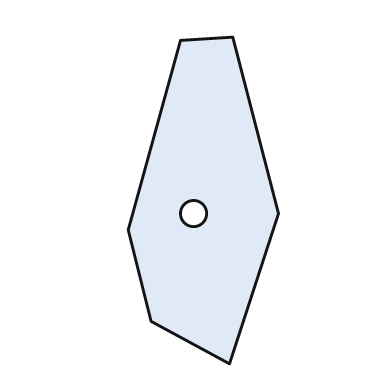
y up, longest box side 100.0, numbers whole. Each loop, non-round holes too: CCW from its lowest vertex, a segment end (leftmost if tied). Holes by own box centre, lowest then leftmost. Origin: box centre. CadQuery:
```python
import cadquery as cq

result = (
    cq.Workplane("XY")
    .moveTo(8.0, -50.0)
    .lineTo(23.0, -4.0)
    .lineTo(9.0, 50.0)
    .lineTo(-7.0, 49.0)
    .lineTo(-23.0, -9.0)
    .lineTo(-16.0, -37.0)
    .close()
    .moveTo(-3.0, -4.0)
    .circle(4.0)
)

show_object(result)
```